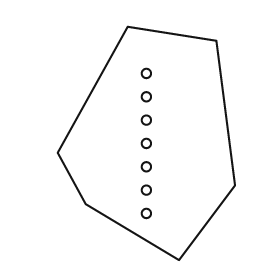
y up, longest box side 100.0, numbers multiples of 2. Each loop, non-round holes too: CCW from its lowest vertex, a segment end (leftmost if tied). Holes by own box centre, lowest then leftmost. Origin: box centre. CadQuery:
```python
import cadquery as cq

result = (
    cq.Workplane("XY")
    .moveTo(14.0, -50.0)
    .lineTo(38.0, -18.0)
    .lineTo(30.0, 44.0)
    .lineTo(-8.0, 50.0)
    .lineTo(-38.0, -4.0)
    .lineTo(-26.0, -26.0)
    .close()
    .moveTo(0.0, -30.0)
    .circle(2.0)
    .moveTo(0.0, -20.0)
    .circle(2.0)
    .moveTo(0.0, -10.0)
    .circle(2.0)
    .moveTo(0.0, 0.0)
    .circle(2.0)
    .moveTo(0.0, 10.0)
    .circle(2.0)
    .moveTo(0.0, 20.0)
    .circle(2.0)
    .moveTo(0.0, 30.0)
    .circle(2.0)
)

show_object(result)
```